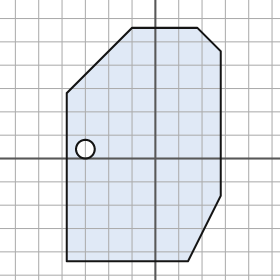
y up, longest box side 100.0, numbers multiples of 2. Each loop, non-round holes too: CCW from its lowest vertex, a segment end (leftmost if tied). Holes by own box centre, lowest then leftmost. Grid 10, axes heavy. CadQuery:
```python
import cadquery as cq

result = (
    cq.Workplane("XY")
    .moveTo(-38.0, -44.0)
    .lineTo(14.0, -44.0)
    .lineTo(28.0, -16.0)
    .lineTo(28.0, 46.0)
    .lineTo(18.0, 56.0)
    .lineTo(-10.0, 56.0)
    .lineTo(-38.0, 28.0)
    .close()
    .moveTo(-30.0, 4.0)
    .circle(4.0)
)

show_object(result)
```